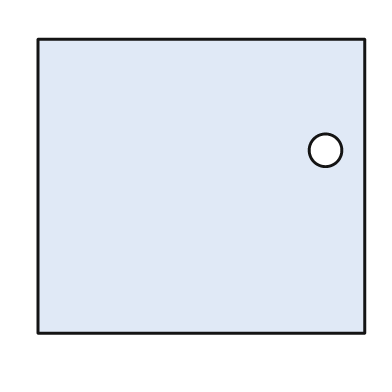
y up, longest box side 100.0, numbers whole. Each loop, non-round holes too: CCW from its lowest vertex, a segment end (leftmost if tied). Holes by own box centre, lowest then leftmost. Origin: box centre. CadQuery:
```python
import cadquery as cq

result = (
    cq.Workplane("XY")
    .moveTo(-50.0, -45.0)
    .lineTo(50.0, -45.0)
    .lineTo(50.0, 45.0)
    .lineTo(-50.0, 45.0)
    .close()
    .moveTo(38.0, 11.0)
    .circle(5.0)
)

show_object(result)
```